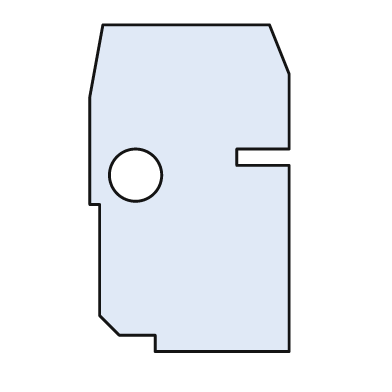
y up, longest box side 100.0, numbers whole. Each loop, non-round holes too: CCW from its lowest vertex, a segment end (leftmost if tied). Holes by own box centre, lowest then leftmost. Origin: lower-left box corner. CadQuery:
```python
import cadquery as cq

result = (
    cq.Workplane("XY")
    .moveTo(20.0, 0.0)
    .lineTo(61.0, 0.0)
    .lineTo(61.0, 57.0)
    .lineTo(45.0, 57.0)
    .lineTo(45.0, 62.0)
    .lineTo(61.0, 62.0)
    .lineTo(61.0, 85.0)
    .lineTo(55.0, 100.0)
    .lineTo(4.0, 100.0)
    .lineTo(0.0, 78.0)
    .lineTo(0.0, 45.0)
    .lineTo(3.0, 45.0)
    .lineTo(3.0, 11.0)
    .lineTo(9.0, 5.0)
    .lineTo(20.0, 5.0)
    .close()
    .moveTo(14.0, 54.0)
    .circle(8.0)
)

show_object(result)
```